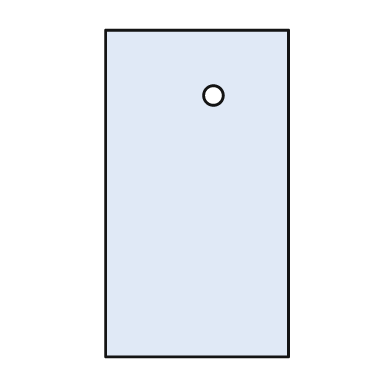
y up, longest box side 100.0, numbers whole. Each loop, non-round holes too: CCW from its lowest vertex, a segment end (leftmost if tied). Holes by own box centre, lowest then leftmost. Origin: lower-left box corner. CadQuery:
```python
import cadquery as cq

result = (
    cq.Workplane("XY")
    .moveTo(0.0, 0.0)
    .lineTo(56.0, 0.0)
    .lineTo(56.0, 100.0)
    .lineTo(0.0, 100.0)
    .close()
    .moveTo(33.0, 80.0)
    .circle(3.0)
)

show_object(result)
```